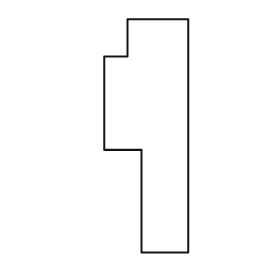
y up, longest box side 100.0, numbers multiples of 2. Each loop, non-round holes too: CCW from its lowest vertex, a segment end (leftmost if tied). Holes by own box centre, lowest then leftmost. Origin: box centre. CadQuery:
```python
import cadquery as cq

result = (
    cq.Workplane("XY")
    .moveTo(-2.0, -50.0)
    .lineTo(18.0, -50.0)
    .lineTo(18.0, 50.0)
    .lineTo(-8.0, 50.0)
    .lineTo(-8.0, 34.0)
    .lineTo(-18.0, 34.0)
    .lineTo(-18.0, -6.0)
    .lineTo(-2.0, -6.0)
    .close()
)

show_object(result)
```